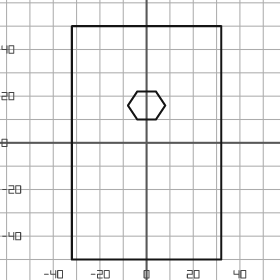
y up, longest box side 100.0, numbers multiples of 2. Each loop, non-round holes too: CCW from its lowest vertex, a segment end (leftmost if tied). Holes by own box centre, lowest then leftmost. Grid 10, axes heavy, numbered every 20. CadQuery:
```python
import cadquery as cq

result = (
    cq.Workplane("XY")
    .moveTo(-32.0, -50.0)
    .lineTo(32.0, -50.0)
    .lineTo(32.0, 50.0)
    .lineTo(-32.0, 50.0)
    .close()
    .moveTo(-4.0, 10.0)
    .lineTo(4.0, 10.0)
    .lineTo(8.0, 16.0)
    .lineTo(4.0, 22.0)
    .lineTo(-4.0, 22.0)
    .lineTo(-8.0, 16.0)
    .close()
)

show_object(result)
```